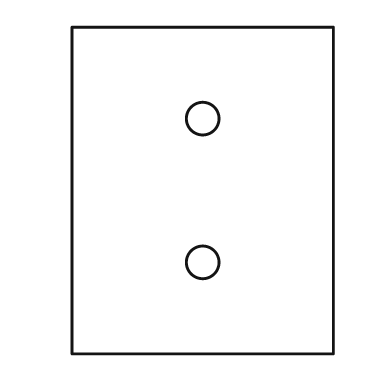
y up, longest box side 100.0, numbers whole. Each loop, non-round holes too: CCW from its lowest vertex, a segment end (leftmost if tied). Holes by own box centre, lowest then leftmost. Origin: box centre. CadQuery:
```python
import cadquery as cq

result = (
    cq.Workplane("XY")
    .moveTo(-40.0, -50.0)
    .lineTo(40.0, -50.0)
    .lineTo(40.0, 50.0)
    .lineTo(-40.0, 50.0)
    .close()
    .moveTo(0.0, -22.0)
    .circle(5.0)
    .moveTo(0.0, 22.0)
    .circle(5.0)
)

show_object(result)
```